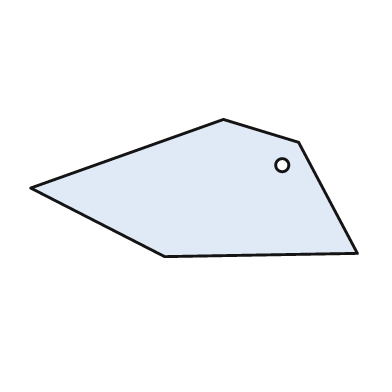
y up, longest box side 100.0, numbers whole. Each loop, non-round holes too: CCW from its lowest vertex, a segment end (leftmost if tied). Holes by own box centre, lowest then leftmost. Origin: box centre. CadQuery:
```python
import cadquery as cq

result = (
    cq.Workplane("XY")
    .moveTo(-9.0, -21.0)
    .lineTo(50.0, -20.0)
    .lineTo(32.0, 14.0)
    .lineTo(9.0, 21.0)
    .lineTo(-50.0, 0.0)
    .close()
    .moveTo(27.0, 7.0)
    .circle(2.0)
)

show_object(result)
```